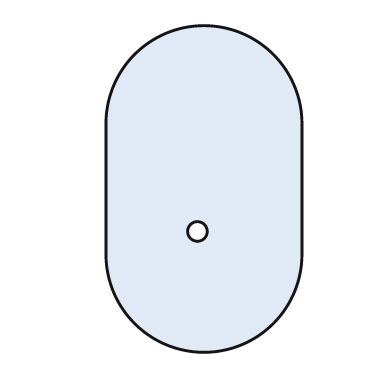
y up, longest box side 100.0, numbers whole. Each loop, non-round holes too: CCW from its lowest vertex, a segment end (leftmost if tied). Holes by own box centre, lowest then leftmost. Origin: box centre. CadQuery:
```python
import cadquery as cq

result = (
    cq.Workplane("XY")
    .moveTo(-30.0, -20.0)
    .threePointArc((0.0, -50.0), (30.0, -20.0))
    .lineTo(30.0, 20.0)
    .threePointArc((0.0, 50.0), (-30.0, 20.0))
    .close()
    .moveTo(-2.0, -13.0)
    .circle(3.0)
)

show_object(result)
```